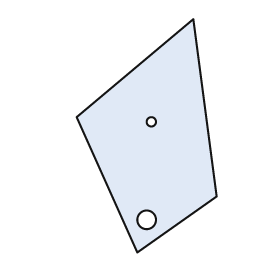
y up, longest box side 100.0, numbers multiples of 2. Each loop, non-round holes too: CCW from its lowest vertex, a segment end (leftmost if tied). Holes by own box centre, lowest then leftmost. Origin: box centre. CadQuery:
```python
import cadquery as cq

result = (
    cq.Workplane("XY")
    .moveTo(-4.0, -50.0)
    .lineTo(30.0, -26.0)
    .lineTo(20.0, 50.0)
    .lineTo(-30.0, 8.0)
    .close()
    .moveTo(0.0, -36.0)
    .circle(4.0)
    .moveTo(2.0, 6.0)
    .circle(2.0)
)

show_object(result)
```